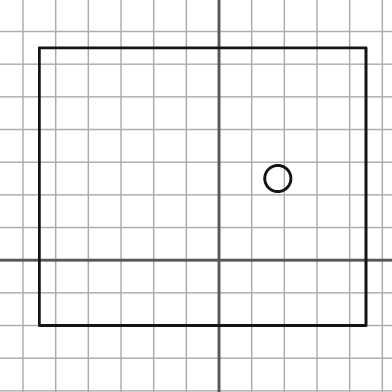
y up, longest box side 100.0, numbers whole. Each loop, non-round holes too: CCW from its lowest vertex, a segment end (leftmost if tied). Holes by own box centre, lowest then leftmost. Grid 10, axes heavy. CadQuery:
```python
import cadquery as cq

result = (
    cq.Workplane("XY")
    .moveTo(-55.0, -20.0)
    .lineTo(45.0, -20.0)
    .lineTo(45.0, 65.0)
    .lineTo(-55.0, 65.0)
    .close()
    .moveTo(18.0, 25.0)
    .circle(4.0)
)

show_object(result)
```